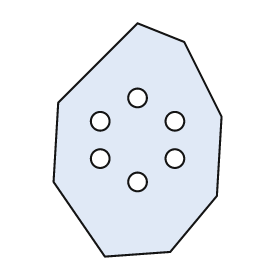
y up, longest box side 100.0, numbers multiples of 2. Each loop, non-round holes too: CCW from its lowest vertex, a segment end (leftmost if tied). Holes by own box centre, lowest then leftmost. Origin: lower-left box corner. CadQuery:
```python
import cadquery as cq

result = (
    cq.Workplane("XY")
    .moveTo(22.0, 0.0)
    .lineTo(50.0, 2.0)
    .lineTo(70.0, 26.0)
    .lineTo(72.0, 60.0)
    .lineTo(56.0, 92.0)
    .lineTo(36.0, 100.0)
    .lineTo(2.0, 66.0)
    .lineTo(0.0, 32.0)
    .close()
    .moveTo(36.0, 32.0)
    .circle(4.0)
    .moveTo(20.0, 42.0)
    .circle(4.0)
    .moveTo(52.0, 42.0)
    .circle(4.0)
    .moveTo(20.0, 58.0)
    .circle(4.0)
    .moveTo(52.0, 58.0)
    .circle(4.0)
    .moveTo(36.0, 68.0)
    .circle(4.0)
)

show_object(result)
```